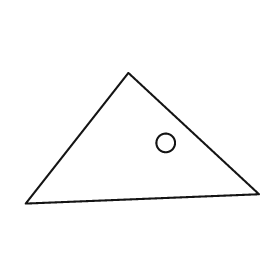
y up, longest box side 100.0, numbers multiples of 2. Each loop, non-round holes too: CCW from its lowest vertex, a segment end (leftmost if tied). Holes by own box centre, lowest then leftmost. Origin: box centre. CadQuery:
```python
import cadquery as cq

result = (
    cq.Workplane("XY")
    .moveTo(-50.0, -28.0)
    .lineTo(50.0, -24.0)
    .lineTo(-6.0, 28.0)
    .close()
    .moveTo(10.0, -2.0)
    .circle(4.0)
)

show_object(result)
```